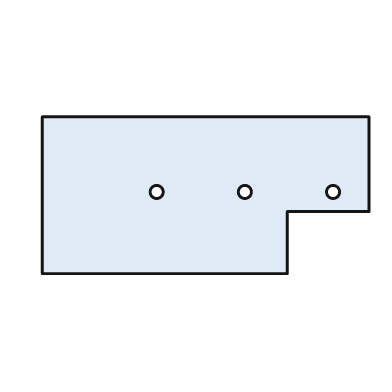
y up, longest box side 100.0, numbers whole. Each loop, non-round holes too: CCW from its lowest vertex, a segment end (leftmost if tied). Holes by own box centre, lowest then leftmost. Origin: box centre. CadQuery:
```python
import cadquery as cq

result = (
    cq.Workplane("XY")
    .moveTo(-50.0, -24.0)
    .lineTo(25.0, -24.0)
    .lineTo(25.0, -5.0)
    .lineTo(50.0, -5.0)
    .lineTo(50.0, 24.0)
    .lineTo(-50.0, 24.0)
    .close()
    .moveTo(-15.0, 1.0)
    .circle(2.0)
    .moveTo(12.0, 1.0)
    .circle(2.0)
    .moveTo(39.0, 1.0)
    .circle(2.0)
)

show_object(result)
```